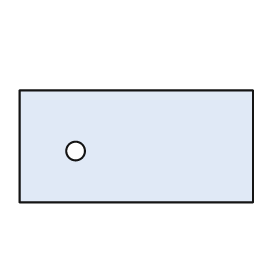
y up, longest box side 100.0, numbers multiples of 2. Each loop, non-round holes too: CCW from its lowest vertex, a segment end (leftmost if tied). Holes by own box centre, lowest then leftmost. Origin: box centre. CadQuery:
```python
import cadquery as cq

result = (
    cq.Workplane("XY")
    .moveTo(-50.0, -24.0)
    .lineTo(50.0, -24.0)
    .lineTo(50.0, 24.0)
    .lineTo(-50.0, 24.0)
    .close()
    .moveTo(-26.0, -2.0)
    .circle(4.0)
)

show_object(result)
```